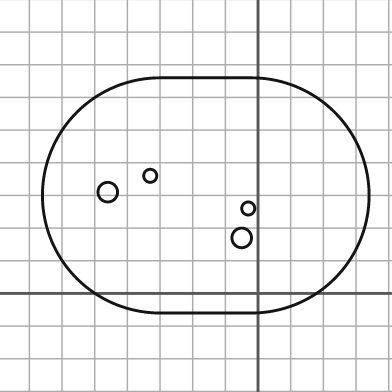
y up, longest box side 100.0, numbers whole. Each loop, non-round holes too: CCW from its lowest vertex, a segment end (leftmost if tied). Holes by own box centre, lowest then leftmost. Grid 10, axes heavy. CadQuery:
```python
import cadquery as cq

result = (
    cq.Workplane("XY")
    .moveTo(-30.0, -6.0)
    .lineTo(-2.0, -6.0)
    .threePointArc((34.0, 30.0), (-2.0, 66.0))
    .lineTo(-30.0, 66.0)
    .threePointArc((-66.0, 30.0), (-30.0, -6.0))
    .close()
    .moveTo(-5.0, 17.0)
    .circle(3.0)
    .moveTo(-3.0, 26.0)
    .circle(2.0)
    .moveTo(-46.0, 31.0)
    .circle(3.0)
    .moveTo(-33.0, 36.0)
    .circle(2.0)
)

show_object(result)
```